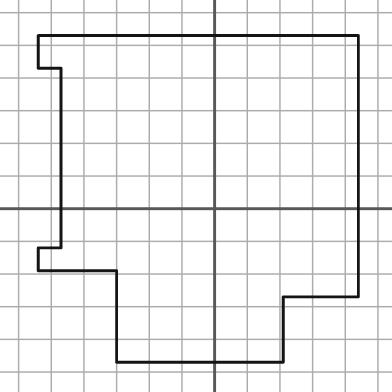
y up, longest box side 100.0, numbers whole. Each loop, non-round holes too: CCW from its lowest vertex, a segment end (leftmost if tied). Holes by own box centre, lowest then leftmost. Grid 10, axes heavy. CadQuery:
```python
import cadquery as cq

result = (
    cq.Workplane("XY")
    .moveTo(-30.0, -47.0)
    .lineTo(21.0, -47.0)
    .lineTo(21.0, -27.0)
    .lineTo(44.0, -27.0)
    .lineTo(44.0, 53.0)
    .lineTo(-54.0, 53.0)
    .lineTo(-54.0, 43.0)
    .lineTo(-47.0, 43.0)
    .lineTo(-47.0, -12.0)
    .lineTo(-54.0, -12.0)
    .lineTo(-54.0, -19.0)
    .lineTo(-30.0, -19.0)
    .close()
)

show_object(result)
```